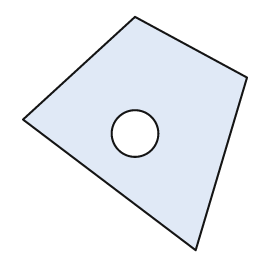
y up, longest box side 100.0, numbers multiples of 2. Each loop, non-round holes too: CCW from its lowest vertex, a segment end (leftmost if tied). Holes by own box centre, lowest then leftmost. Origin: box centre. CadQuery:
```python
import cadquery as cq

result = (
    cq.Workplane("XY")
    .moveTo(26.0, -50.0)
    .lineTo(48.0, 24.0)
    .lineTo(0.0, 50.0)
    .lineTo(-48.0, 6.0)
    .close()
    .moveTo(0.0, 0.0)
    .circle(10.0)
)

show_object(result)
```